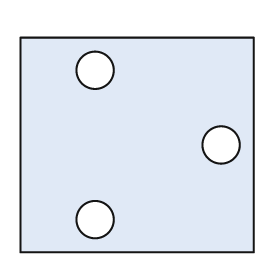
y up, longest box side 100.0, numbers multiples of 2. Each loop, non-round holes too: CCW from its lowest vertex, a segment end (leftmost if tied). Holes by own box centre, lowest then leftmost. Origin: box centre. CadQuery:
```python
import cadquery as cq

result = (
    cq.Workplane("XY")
    .moveTo(-50.0, -46.0)
    .lineTo(50.0, -46.0)
    .lineTo(50.0, 46.0)
    .lineTo(-50.0, 46.0)
    .close()
    .moveTo(-18.0, -32.0)
    .circle(8.0)
    .moveTo(36.0, 0.0)
    .circle(8.0)
    .moveTo(-18.0, 32.0)
    .circle(8.0)
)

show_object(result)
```